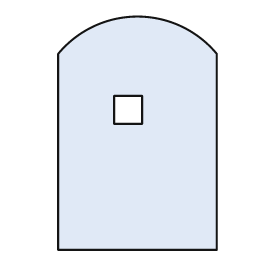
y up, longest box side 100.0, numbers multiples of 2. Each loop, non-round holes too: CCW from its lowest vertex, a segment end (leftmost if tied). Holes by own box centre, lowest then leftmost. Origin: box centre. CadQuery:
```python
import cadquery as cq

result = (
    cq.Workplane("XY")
    .moveTo(-34.0, -50.0)
    .lineTo(34.0, -50.0)
    .lineTo(34.0, 34.0)
    .threePointArc((0.0, 50.0), (-34.0, 34.0))
    .close()
    .moveTo(-10.0, 4.0)
    .lineTo(2.0, 4.0)
    .lineTo(2.0, 16.0)
    .lineTo(-10.0, 16.0)
    .close()
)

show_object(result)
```